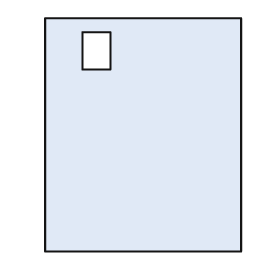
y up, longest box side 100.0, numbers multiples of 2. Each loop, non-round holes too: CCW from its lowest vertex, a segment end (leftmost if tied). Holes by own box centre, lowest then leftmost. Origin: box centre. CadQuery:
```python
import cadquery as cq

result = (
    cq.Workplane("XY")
    .moveTo(-42.0, -50.0)
    .lineTo(42.0, -50.0)
    .lineTo(42.0, 50.0)
    .lineTo(-42.0, 50.0)
    .close()
    .moveTo(-26.0, 28.0)
    .lineTo(-14.0, 28.0)
    .lineTo(-14.0, 44.0)
    .lineTo(-26.0, 44.0)
    .close()
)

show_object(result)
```